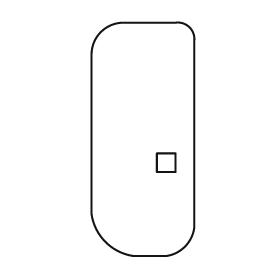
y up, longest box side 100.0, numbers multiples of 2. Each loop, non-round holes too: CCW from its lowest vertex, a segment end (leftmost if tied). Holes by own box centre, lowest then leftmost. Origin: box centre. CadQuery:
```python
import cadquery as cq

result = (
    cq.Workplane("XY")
    .moveTo(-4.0, -50.0)
    .lineTo(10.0, -50.0)
    .threePointArc((18.0, -46.0), (22.0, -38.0))
    .lineTo(22.0, 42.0)
    .threePointArc((20.0, 48.0), (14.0, 50.0))
    .lineTo(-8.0, 50.0)
    .threePointArc((-18.0, 46.0), (-22.0, 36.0))
    .lineTo(-22.0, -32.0)
    .threePointArc((-16.0, -44.0), (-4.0, -50.0))
    .close()
    .moveTo(6.0, -14.0)
    .lineTo(14.0, -14.0)
    .lineTo(14.0, -6.0)
    .lineTo(6.0, -6.0)
    .close()
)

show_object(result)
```